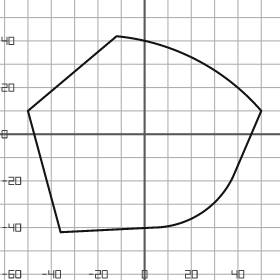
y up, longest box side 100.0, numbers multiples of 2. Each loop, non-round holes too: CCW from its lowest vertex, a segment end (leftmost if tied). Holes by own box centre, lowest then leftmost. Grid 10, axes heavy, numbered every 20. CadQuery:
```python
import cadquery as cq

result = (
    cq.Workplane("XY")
    .moveTo(-36.0, -42.0)
    .lineTo(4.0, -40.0)
    .threePointArc((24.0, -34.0), (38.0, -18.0))
    .lineTo(50.0, 10.0)
    .threePointArc((22.0, 32.0), (-12.0, 42.0))
    .lineTo(-50.0, 10.0)
    .close()
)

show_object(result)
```